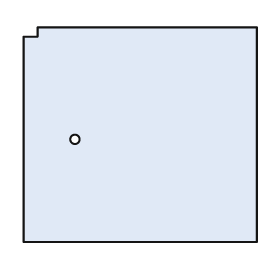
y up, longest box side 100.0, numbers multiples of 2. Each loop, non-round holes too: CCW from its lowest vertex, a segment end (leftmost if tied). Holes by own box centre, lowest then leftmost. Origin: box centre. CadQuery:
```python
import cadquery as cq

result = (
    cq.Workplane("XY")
    .moveTo(-50.0, -46.0)
    .lineTo(50.0, -46.0)
    .lineTo(50.0, 46.0)
    .lineTo(-44.0, 46.0)
    .lineTo(-44.0, 42.0)
    .lineTo(-50.0, 42.0)
    .close()
    .moveTo(-28.0, -2.0)
    .circle(2.0)
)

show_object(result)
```